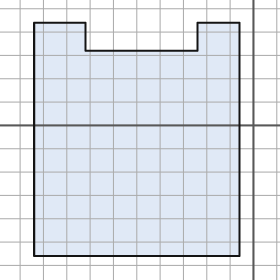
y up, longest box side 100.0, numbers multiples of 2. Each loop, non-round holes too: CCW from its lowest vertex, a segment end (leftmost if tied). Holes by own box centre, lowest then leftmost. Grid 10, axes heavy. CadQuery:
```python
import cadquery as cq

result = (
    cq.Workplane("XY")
    .moveTo(-94.0, -56.0)
    .lineTo(-6.0, -56.0)
    .lineTo(-6.0, 44.0)
    .lineTo(-24.0, 44.0)
    .lineTo(-24.0, 32.0)
    .lineTo(-72.0, 32.0)
    .lineTo(-72.0, 44.0)
    .lineTo(-94.0, 44.0)
    .close()
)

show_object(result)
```